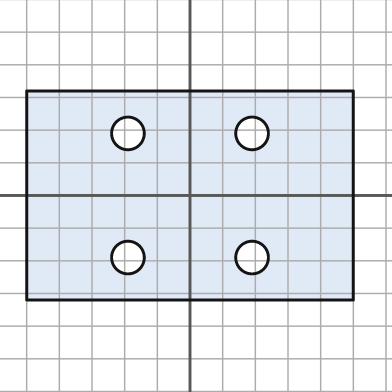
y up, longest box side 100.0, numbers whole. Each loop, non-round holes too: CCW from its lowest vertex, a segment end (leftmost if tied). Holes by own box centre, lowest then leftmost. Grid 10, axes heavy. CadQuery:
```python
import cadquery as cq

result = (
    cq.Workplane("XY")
    .moveTo(-50.0, -32.0)
    .lineTo(50.0, -32.0)
    .lineTo(50.0, 32.0)
    .lineTo(-50.0, 32.0)
    .close()
    .moveTo(-19.0, -19.0)
    .circle(5.0)
    .moveTo(19.0, -19.0)
    .circle(5.0)
    .moveTo(-19.0, 19.0)
    .circle(5.0)
    .moveTo(19.0, 19.0)
    .circle(5.0)
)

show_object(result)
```